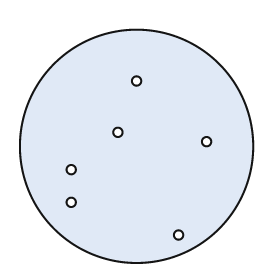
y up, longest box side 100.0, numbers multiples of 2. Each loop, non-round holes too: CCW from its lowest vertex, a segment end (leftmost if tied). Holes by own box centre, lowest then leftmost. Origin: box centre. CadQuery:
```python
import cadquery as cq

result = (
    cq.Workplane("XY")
    .moveTo(0.0, 0.0)
    .circle(50.0)
    .moveTo(18.0, -38.0)
    .circle(2.0)
    .moveTo(-28.0, -24.0)
    .circle(2.0)
    .moveTo(-28.0, -10.0)
    .circle(2.0)
    .moveTo(30.0, 2.0)
    .circle(2.0)
    .moveTo(-8.0, 6.0)
    .circle(2.0)
    .moveTo(0.0, 28.0)
    .circle(2.0)
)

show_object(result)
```